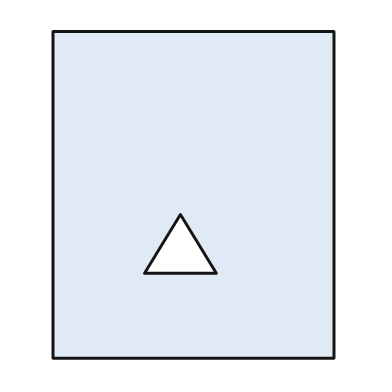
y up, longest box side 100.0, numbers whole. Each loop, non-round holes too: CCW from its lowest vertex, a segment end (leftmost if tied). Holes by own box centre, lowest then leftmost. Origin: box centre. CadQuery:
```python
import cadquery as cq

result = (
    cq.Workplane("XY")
    .moveTo(-43.0, -50.0)
    .lineTo(43.0, -50.0)
    .lineTo(43.0, 50.0)
    .lineTo(-43.0, 50.0)
    .close()
    .moveTo(-15.0, -24.0)
    .lineTo(7.0, -24.0)
    .lineTo(-4.0, -6.0)
    .close()
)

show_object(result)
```